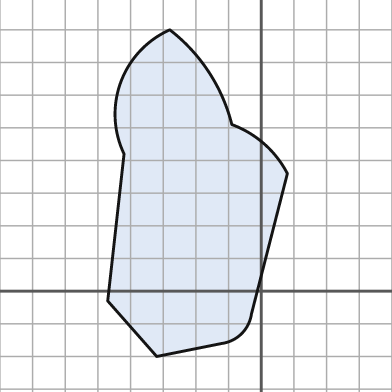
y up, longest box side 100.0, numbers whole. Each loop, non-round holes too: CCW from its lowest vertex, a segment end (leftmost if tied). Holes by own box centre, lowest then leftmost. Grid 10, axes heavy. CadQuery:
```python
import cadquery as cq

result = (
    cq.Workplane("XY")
    .moveTo(-32.0, -20.0)
    .lineTo(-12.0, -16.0)
    .threePointArc((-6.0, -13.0), (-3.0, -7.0))
    .lineTo(8.0, 36.0)
    .threePointArc((1.0, 45.0), (-9.0, 51.0))
    .threePointArc((-16.0, 67.0), (-28.0, 80.0))
    .threePointArc((-43.0, 64.0), (-42.0, 42.0))
    .lineTo(-47.0, -3.0)
    .close()
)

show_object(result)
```